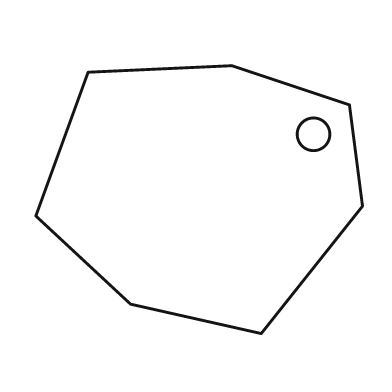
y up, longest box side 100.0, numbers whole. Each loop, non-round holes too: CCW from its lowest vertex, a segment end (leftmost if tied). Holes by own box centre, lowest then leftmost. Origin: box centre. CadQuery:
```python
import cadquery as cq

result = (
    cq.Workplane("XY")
    .moveTo(19.0, -41.0)
    .lineTo(50.0, -2.0)
    .lineTo(46.0, 29.0)
    .lineTo(10.0, 41.0)
    .lineTo(-34.0, 39.0)
    .lineTo(-50.0, -5.0)
    .lineTo(-21.0, -32.0)
    .close()
    .moveTo(35.0, 20.0)
    .circle(5.0)
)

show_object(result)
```